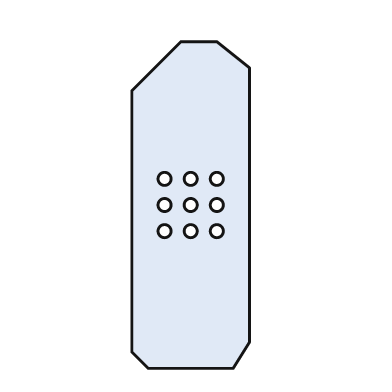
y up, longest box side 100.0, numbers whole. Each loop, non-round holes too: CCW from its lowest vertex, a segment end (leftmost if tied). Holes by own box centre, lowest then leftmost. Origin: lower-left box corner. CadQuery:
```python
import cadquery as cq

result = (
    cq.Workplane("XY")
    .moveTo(5.0, 0.0)
    .lineTo(31.0, 0.0)
    .lineTo(36.0, 8.0)
    .lineTo(36.0, 92.0)
    .lineTo(26.0, 100.0)
    .lineTo(15.0, 100.0)
    .lineTo(0.0, 85.0)
    .lineTo(0.0, 5.0)
    .close()
    .moveTo(10.0, 42.0)
    .circle(2.0)
    .moveTo(18.0, 42.0)
    .circle(2.0)
    .moveTo(26.0, 42.0)
    .circle(2.0)
    .moveTo(10.0, 50.0)
    .circle(2.0)
    .moveTo(18.0, 50.0)
    .circle(2.0)
    .moveTo(26.0, 50.0)
    .circle(2.0)
    .moveTo(10.0, 58.0)
    .circle(2.0)
    .moveTo(18.0, 58.0)
    .circle(2.0)
    .moveTo(26.0, 58.0)
    .circle(2.0)
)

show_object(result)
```